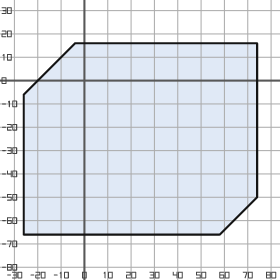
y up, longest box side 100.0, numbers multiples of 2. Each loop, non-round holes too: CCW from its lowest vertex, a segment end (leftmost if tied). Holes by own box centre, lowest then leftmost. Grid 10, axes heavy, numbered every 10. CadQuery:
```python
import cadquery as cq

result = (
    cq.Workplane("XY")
    .moveTo(-26.0, -66.0)
    .lineTo(58.0, -66.0)
    .lineTo(74.0, -50.0)
    .lineTo(74.0, 16.0)
    .lineTo(-4.0, 16.0)
    .lineTo(-26.0, -6.0)
    .close()
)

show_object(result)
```